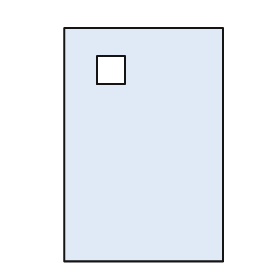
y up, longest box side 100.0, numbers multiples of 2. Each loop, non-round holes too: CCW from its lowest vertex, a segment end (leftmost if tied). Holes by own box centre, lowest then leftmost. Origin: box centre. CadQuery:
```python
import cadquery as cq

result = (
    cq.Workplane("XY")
    .moveTo(-34.0, -50.0)
    .lineTo(34.0, -50.0)
    .lineTo(34.0, 50.0)
    .lineTo(-34.0, 50.0)
    .close()
    .moveTo(-20.0, 26.0)
    .lineTo(-8.0, 26.0)
    .lineTo(-8.0, 38.0)
    .lineTo(-20.0, 38.0)
    .close()
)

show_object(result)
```